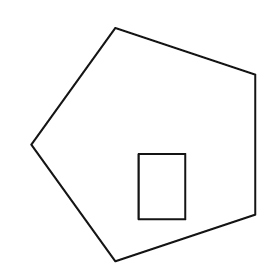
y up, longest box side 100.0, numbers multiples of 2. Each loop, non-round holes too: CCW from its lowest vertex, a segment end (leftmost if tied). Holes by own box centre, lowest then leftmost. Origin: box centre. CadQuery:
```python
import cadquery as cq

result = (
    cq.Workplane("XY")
    .moveTo(-12.0, -50.0)
    .lineTo(48.0, -30.0)
    .lineTo(48.0, 30.0)
    .lineTo(-12.0, 50.0)
    .lineTo(-48.0, 0.0)
    .close()
    .moveTo(-2.0, -32.0)
    .lineTo(18.0, -32.0)
    .lineTo(18.0, -4.0)
    .lineTo(-2.0, -4.0)
    .close()
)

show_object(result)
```